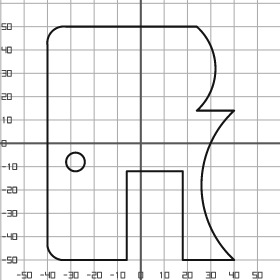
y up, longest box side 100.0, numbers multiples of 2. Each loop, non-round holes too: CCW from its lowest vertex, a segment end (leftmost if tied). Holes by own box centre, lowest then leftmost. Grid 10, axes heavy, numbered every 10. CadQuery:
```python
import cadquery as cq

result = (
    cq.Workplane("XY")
    .moveTo(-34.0, -50.0)
    .lineTo(-6.0, -50.0)
    .lineTo(-6.0, -12.0)
    .lineTo(18.0, -12.0)
    .lineTo(18.0, -50.0)
    .lineTo(40.0, -50.0)
    .threePointArc((26.0, -18.0), (40.0, 14.0))
    .lineTo(24.0, 14.0)
    .threePointArc((32.0, 32.0), (24.0, 50.0))
    .lineTo(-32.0, 50.0)
    .threePointArc((-38.0, 48.0), (-40.0, 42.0))
    .lineTo(-40.0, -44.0)
    .threePointArc((-38.0, -48.0), (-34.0, -50.0))
    .close()
    .moveTo(-28.0, -8.0)
    .circle(4.0)
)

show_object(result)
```